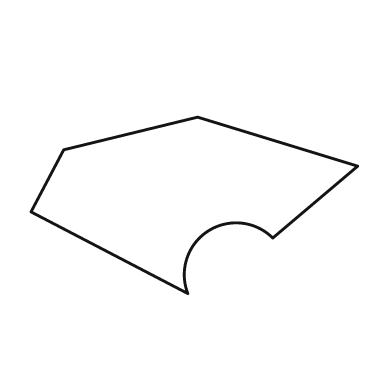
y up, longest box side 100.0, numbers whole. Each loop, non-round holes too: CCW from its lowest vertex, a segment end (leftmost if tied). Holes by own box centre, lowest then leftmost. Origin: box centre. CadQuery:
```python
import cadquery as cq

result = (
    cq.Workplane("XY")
    .moveTo(-2.0, -27.0)
    .threePointArc((4.0, -8.0), (24.0, -10.0))
    .lineTo(50.0, 12.0)
    .lineTo(1.0, 27.0)
    .lineTo(-40.0, 17.0)
    .lineTo(-50.0, -2.0)
    .close()
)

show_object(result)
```